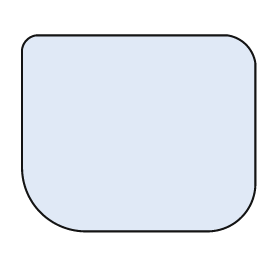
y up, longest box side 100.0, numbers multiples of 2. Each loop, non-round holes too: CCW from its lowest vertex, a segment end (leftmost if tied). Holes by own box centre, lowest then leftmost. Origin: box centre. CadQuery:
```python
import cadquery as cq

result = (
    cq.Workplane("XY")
    .moveTo(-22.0, -42.0)
    .lineTo(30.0, -42.0)
    .threePointArc((44.0, -36.0), (50.0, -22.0))
    .lineTo(50.0, 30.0)
    .threePointArc((46.0, 38.0), (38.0, 42.0))
    .lineTo(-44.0, 42.0)
    .threePointArc((-48.0, 40.0), (-50.0, 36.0))
    .lineTo(-50.0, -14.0)
    .threePointArc((-42.0, -34.0), (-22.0, -42.0))
    .close()
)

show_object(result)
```